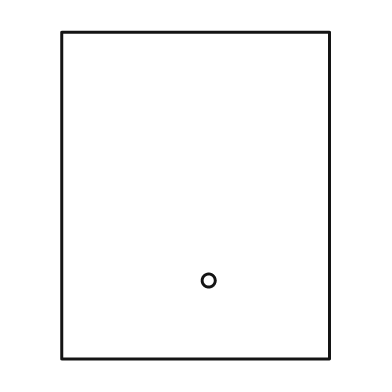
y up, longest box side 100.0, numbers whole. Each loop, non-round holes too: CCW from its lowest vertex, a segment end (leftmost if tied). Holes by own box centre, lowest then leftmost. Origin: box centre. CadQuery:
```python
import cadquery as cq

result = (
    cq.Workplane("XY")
    .moveTo(-41.0, -50.0)
    .lineTo(41.0, -50.0)
    .lineTo(41.0, 50.0)
    .lineTo(-41.0, 50.0)
    .close()
    .moveTo(4.0, -26.0)
    .circle(2.0)
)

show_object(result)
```